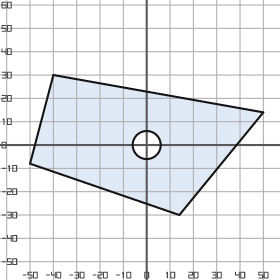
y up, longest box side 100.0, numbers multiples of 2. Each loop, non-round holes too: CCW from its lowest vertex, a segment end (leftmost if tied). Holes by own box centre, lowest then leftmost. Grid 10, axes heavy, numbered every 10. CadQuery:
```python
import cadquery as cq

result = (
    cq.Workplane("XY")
    .moveTo(14.0, -30.0)
    .lineTo(50.0, 14.0)
    .lineTo(-40.0, 30.0)
    .lineTo(-50.0, -8.0)
    .close()
    .moveTo(0.0, 0.0)
    .circle(6.0)
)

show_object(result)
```